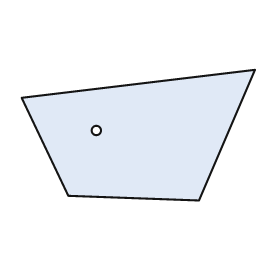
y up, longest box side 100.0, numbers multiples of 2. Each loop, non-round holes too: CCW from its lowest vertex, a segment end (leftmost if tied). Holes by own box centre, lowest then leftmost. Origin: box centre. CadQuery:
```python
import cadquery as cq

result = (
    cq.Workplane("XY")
    .moveTo(26.0, -28.0)
    .lineTo(50.0, 28.0)
    .lineTo(-50.0, 16.0)
    .lineTo(-30.0, -26.0)
    .close()
    .moveTo(-18.0, 2.0)
    .circle(2.0)
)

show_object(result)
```